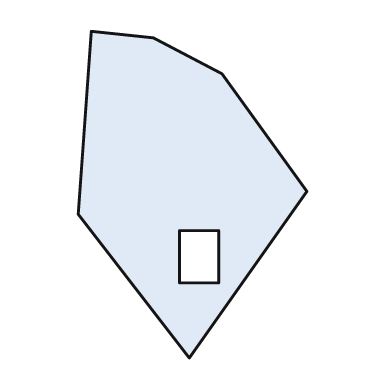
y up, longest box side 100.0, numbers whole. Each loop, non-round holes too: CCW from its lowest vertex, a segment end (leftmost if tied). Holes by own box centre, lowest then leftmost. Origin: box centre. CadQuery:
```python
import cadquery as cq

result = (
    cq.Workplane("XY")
    .moveTo(-1.0, -50.0)
    .lineTo(35.0, 1.0)
    .lineTo(9.0, 37.0)
    .lineTo(-12.0, 48.0)
    .lineTo(-31.0, 50.0)
    .lineTo(-35.0, -6.0)
    .close()
    .moveTo(-4.0, -27.0)
    .lineTo(8.0, -27.0)
    .lineTo(8.0, -11.0)
    .lineTo(-4.0, -11.0)
    .close()
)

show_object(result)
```